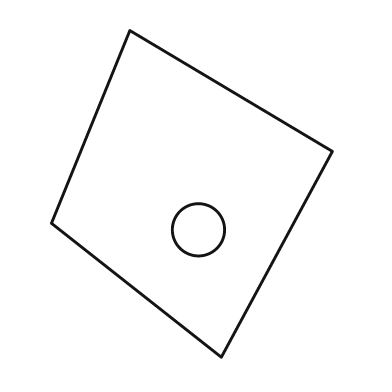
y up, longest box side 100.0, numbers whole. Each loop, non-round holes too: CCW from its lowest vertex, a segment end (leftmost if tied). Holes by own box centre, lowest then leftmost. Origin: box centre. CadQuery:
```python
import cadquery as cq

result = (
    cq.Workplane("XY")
    .moveTo(9.0, -50.0)
    .lineTo(43.0, 13.0)
    .lineTo(-19.0, 50.0)
    .lineTo(-43.0, -9.0)
    .close()
    .moveTo(2.0, -11.0)
    .circle(8.0)
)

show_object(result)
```